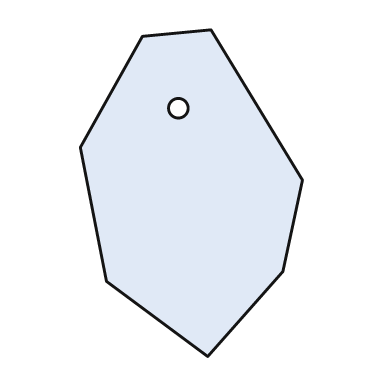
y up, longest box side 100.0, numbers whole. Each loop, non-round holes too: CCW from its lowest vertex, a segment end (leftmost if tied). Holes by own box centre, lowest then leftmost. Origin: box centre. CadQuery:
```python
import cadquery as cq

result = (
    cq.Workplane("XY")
    .moveTo(5.0, -50.0)
    .lineTo(28.0, -24.0)
    .lineTo(34.0, 4.0)
    .lineTo(6.0, 50.0)
    .lineTo(-15.0, 48.0)
    .lineTo(-34.0, 14.0)
    .lineTo(-26.0, -27.0)
    .close()
    .moveTo(-4.0, 26.0)
    .circle(3.0)
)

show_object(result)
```